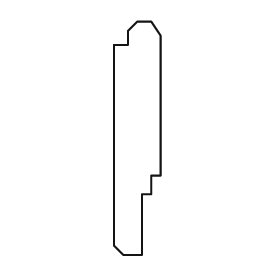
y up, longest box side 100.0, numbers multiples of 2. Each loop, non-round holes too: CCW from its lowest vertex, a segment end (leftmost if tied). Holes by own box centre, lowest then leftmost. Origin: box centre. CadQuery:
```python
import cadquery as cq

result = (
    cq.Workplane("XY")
    .moveTo(-6.0, -50.0)
    .lineTo(2.0, -50.0)
    .lineTo(2.0, -24.0)
    .lineTo(6.0, -24.0)
    .lineTo(6.0, -16.0)
    .lineTo(10.0, -16.0)
    .lineTo(10.0, 44.0)
    .lineTo(6.0, 50.0)
    .lineTo(0.0, 50.0)
    .lineTo(-4.0, 46.0)
    .lineTo(-4.0, 40.0)
    .lineTo(-10.0, 40.0)
    .lineTo(-10.0, -46.0)
    .close()
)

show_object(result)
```